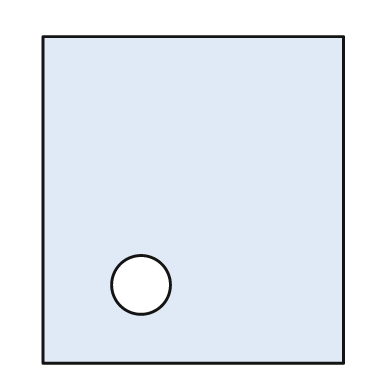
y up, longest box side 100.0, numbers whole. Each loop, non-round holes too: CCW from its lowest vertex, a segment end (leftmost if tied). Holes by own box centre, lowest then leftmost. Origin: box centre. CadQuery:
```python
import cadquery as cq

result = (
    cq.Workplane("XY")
    .moveTo(-46.0, -50.0)
    .lineTo(46.0, -50.0)
    .lineTo(46.0, 50.0)
    .lineTo(-46.0, 50.0)
    .close()
    .moveTo(-16.0, -26.0)
    .circle(9.0)
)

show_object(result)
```